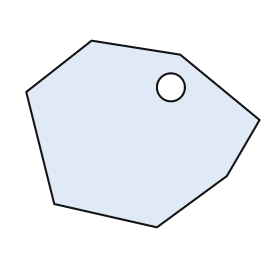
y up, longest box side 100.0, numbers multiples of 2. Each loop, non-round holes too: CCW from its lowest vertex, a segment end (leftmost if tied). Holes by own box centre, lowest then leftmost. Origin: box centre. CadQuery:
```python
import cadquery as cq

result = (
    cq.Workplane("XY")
    .moveTo(6.0, -40.0)
    .lineTo(36.0, -18.0)
    .lineTo(50.0, 6.0)
    .lineTo(16.0, 34.0)
    .lineTo(-22.0, 40.0)
    .lineTo(-50.0, 18.0)
    .lineTo(-38.0, -30.0)
    .close()
    .moveTo(12.0, 20.0)
    .circle(6.0)
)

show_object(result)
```